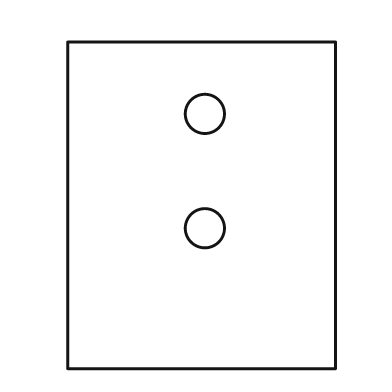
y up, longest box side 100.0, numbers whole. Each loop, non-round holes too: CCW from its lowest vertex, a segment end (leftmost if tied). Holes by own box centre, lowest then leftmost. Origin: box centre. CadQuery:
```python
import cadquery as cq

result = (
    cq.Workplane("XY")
    .moveTo(-41.0, -50.0)
    .lineTo(41.0, -50.0)
    .lineTo(41.0, 50.0)
    .lineTo(-41.0, 50.0)
    .close()
    .moveTo(1.0, -7.0)
    .circle(6.0)
    .moveTo(1.0, 28.0)
    .circle(6.0)
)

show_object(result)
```